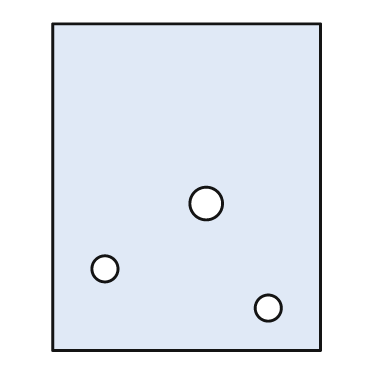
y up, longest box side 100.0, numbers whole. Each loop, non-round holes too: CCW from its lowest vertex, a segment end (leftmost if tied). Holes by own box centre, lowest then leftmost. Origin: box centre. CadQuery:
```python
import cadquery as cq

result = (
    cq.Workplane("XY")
    .moveTo(-41.0, -50.0)
    .lineTo(41.0, -50.0)
    .lineTo(41.0, 50.0)
    .lineTo(-41.0, 50.0)
    .close()
    .moveTo(25.0, -37.0)
    .circle(4.0)
    .moveTo(-25.0, -25.0)
    .circle(4.0)
    .moveTo(6.0, -5.0)
    .circle(5.0)
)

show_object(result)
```